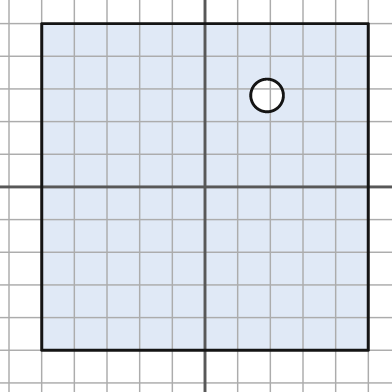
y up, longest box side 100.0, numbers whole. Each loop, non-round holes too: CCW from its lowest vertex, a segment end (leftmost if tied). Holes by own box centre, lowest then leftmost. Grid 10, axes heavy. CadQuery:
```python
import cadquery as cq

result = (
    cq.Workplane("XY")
    .moveTo(-50.0, -50.0)
    .lineTo(50.0, -50.0)
    .lineTo(50.0, 50.0)
    .lineTo(-50.0, 50.0)
    .close()
    .moveTo(19.0, 28.0)
    .circle(5.0)
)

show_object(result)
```